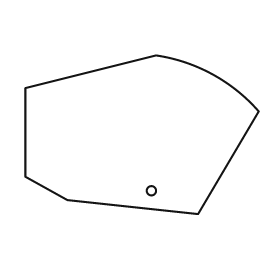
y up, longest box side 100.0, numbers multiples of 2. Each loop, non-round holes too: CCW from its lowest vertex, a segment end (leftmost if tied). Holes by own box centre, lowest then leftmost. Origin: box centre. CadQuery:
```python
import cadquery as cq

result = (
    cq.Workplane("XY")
    .moveTo(24.0, -34.0)
    .lineTo(50.0, 10.0)
    .threePointArc((30.0, 26.0), (6.0, 34.0))
    .lineTo(-50.0, 20.0)
    .lineTo(-50.0, -18.0)
    .lineTo(-32.0, -28.0)
    .close()
    .moveTo(4.0, -24.0)
    .circle(2.0)
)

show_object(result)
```